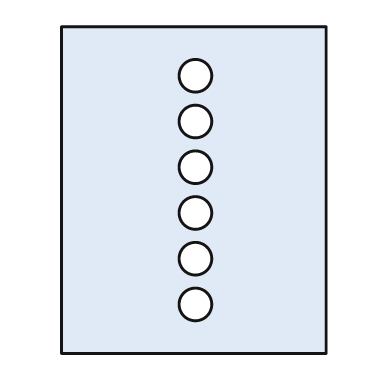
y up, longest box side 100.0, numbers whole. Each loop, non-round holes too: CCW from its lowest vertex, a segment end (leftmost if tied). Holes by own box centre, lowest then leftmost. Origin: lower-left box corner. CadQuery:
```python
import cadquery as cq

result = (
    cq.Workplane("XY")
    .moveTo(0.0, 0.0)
    .lineTo(81.0, 0.0)
    .lineTo(81.0, 100.0)
    .lineTo(0.0, 100.0)
    .close()
    .moveTo(41.0, 15.0)
    .circle(5.0)
    .moveTo(41.0, 29.0)
    .circle(5.0)
    .moveTo(41.0, 43.0)
    .circle(5.0)
    .moveTo(41.0, 57.0)
    .circle(5.0)
    .moveTo(41.0, 71.0)
    .circle(5.0)
    .moveTo(41.0, 85.0)
    .circle(5.0)
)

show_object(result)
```